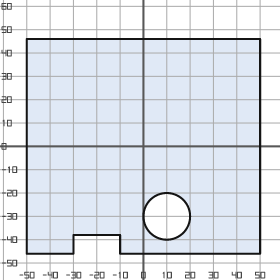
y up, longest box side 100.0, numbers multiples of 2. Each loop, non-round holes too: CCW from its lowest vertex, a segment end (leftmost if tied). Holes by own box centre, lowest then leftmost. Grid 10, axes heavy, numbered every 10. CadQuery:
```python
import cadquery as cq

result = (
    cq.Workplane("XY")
    .moveTo(-50.0, -46.0)
    .lineTo(-30.0, -46.0)
    .lineTo(-30.0, -38.0)
    .lineTo(-10.0, -38.0)
    .lineTo(-10.0, -46.0)
    .lineTo(50.0, -46.0)
    .lineTo(50.0, 46.0)
    .lineTo(-50.0, 46.0)
    .close()
    .moveTo(10.0, -30.0)
    .circle(10.0)
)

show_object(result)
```